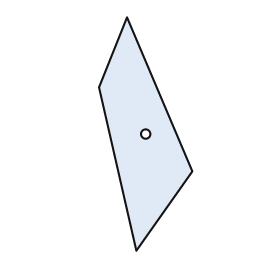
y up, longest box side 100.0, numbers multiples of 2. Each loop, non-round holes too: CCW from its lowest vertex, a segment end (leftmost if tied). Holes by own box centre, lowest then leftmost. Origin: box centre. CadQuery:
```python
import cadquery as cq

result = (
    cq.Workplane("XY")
    .moveTo(-4.0, -50.0)
    .lineTo(20.0, -16.0)
    .lineTo(-8.0, 50.0)
    .lineTo(-20.0, 20.0)
    .close()
    .moveTo(0.0, 0.0)
    .circle(2.0)
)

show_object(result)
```